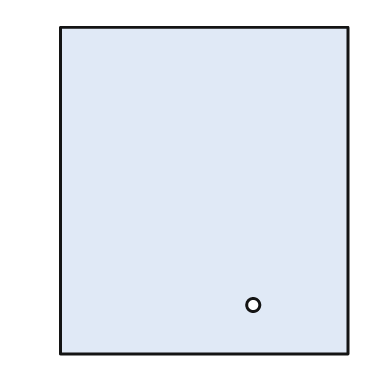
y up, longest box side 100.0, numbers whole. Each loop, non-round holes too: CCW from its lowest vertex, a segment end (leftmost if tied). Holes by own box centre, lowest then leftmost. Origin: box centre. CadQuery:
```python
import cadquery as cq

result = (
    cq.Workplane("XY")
    .moveTo(-44.0, -50.0)
    .lineTo(44.0, -50.0)
    .lineTo(44.0, 50.0)
    .lineTo(-44.0, 50.0)
    .close()
    .moveTo(15.0, -35.0)
    .circle(2.0)
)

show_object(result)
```